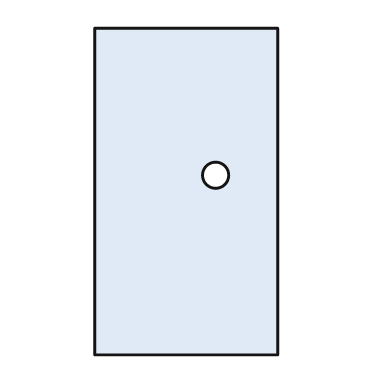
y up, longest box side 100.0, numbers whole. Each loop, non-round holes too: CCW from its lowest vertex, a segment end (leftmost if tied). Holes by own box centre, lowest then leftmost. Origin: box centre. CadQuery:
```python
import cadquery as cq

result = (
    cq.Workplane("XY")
    .moveTo(-28.0, -50.0)
    .lineTo(28.0, -50.0)
    .lineTo(28.0, 50.0)
    .lineTo(-28.0, 50.0)
    .close()
    .moveTo(9.0, 5.0)
    .circle(4.0)
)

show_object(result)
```